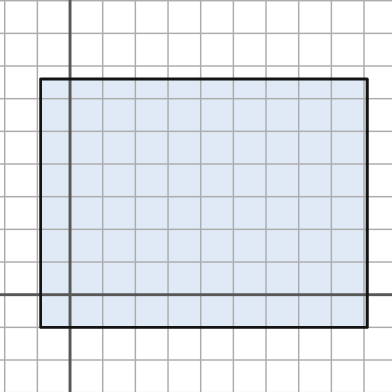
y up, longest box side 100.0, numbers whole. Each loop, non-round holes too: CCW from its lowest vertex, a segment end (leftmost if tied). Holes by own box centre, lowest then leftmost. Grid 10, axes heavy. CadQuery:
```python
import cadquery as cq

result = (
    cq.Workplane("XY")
    .moveTo(-9.0, -10.0)
    .lineTo(91.0, -10.0)
    .lineTo(91.0, 66.0)
    .lineTo(-9.0, 66.0)
    .close()
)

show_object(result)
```